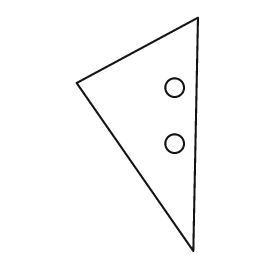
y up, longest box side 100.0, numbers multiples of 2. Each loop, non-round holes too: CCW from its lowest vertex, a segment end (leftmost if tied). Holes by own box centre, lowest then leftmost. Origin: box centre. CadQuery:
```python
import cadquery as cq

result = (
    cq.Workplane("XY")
    .moveTo(24.0, -50.0)
    .lineTo(26.0, 50.0)
    .lineTo(-26.0, 22.0)
    .close()
    .moveTo(16.0, -4.0)
    .circle(4.0)
    .moveTo(16.0, 20.0)
    .circle(4.0)
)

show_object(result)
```